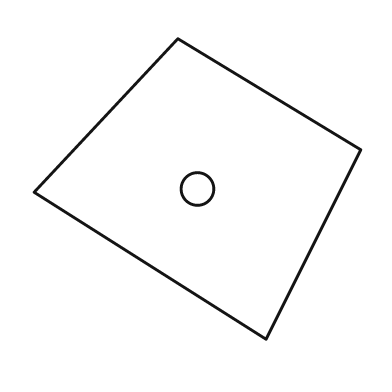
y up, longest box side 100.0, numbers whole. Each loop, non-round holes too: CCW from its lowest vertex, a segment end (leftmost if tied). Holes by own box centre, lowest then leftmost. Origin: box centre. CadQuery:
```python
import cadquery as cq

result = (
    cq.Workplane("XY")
    .moveTo(21.0, -46.0)
    .lineTo(50.0, 12.0)
    .lineTo(-6.0, 46.0)
    .lineTo(-50.0, -1.0)
    .close()
    .moveTo(0.0, 0.0)
    .circle(5.0)
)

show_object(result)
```